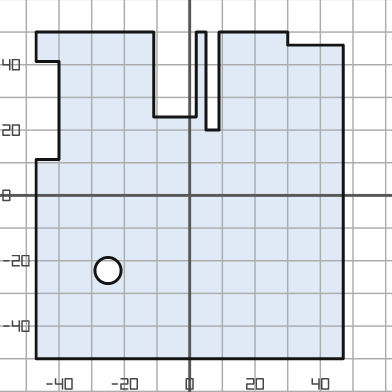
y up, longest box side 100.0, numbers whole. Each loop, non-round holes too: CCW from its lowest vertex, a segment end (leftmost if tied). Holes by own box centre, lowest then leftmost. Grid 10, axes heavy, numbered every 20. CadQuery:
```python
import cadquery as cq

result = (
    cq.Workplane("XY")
    .moveTo(-47.0, -50.0)
    .lineTo(47.0, -50.0)
    .lineTo(47.0, 46.0)
    .lineTo(30.0, 46.0)
    .lineTo(30.0, 50.0)
    .lineTo(9.0, 50.0)
    .lineTo(9.0, 20.0)
    .lineTo(5.0, 20.0)
    .lineTo(5.0, 50.0)
    .lineTo(2.0, 50.0)
    .lineTo(2.0, 24.0)
    .lineTo(-11.0, 24.0)
    .lineTo(-11.0, 50.0)
    .lineTo(-47.0, 50.0)
    .lineTo(-47.0, 41.0)
    .lineTo(-40.0, 41.0)
    .lineTo(-40.0, 11.0)
    .lineTo(-47.0, 11.0)
    .close()
    .moveTo(-25.0, -23.0)
    .circle(4.0)
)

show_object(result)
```